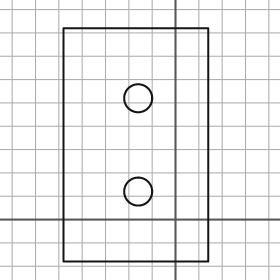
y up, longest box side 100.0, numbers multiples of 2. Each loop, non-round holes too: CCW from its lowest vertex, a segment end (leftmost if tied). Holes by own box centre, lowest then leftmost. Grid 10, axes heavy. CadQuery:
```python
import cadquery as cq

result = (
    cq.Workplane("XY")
    .moveTo(-48.0, -18.0)
    .lineTo(14.0, -18.0)
    .lineTo(14.0, 82.0)
    .lineTo(-48.0, 82.0)
    .close()
    .moveTo(-16.0, 12.0)
    .circle(6.0)
    .moveTo(-16.0, 52.0)
    .circle(6.0)
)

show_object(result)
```